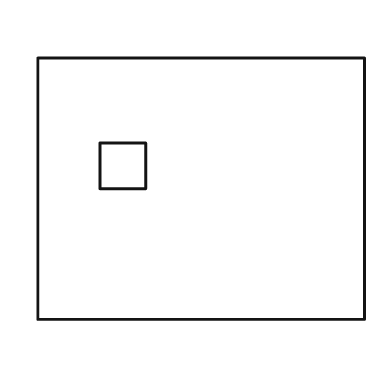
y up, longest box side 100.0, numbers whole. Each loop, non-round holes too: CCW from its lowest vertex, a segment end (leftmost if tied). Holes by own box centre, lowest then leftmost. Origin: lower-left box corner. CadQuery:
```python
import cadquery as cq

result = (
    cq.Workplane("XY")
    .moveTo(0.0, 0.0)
    .lineTo(100.0, 0.0)
    .lineTo(100.0, 80.0)
    .lineTo(0.0, 80.0)
    .close()
    .moveTo(19.0, 40.0)
    .lineTo(33.0, 40.0)
    .lineTo(33.0, 54.0)
    .lineTo(19.0, 54.0)
    .close()
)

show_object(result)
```